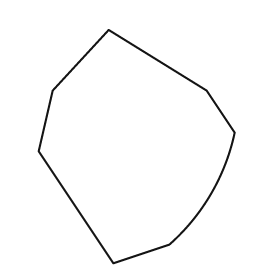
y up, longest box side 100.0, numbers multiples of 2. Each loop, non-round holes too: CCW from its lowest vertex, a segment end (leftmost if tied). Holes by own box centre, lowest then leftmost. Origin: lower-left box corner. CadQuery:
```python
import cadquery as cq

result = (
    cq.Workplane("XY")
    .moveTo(32.0, 0.0)
    .lineTo(56.0, 8.0)
    .threePointArc((74.0, 30.0), (84.0, 56.0))
    .lineTo(72.0, 74.0)
    .lineTo(30.0, 100.0)
    .lineTo(6.0, 74.0)
    .lineTo(0.0, 48.0)
    .close()
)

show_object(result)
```